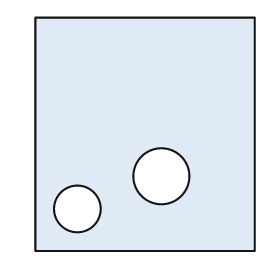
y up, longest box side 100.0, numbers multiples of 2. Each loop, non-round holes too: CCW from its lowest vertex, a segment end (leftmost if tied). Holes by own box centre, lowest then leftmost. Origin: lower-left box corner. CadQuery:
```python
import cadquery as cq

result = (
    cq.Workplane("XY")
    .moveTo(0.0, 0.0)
    .lineTo(94.0, 0.0)
    .lineTo(94.0, 100.0)
    .lineTo(0.0, 100.0)
    .close()
    .moveTo(18.0, 18.0)
    .circle(10.0)
    .moveTo(54.0, 32.0)
    .circle(12.0)
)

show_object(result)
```